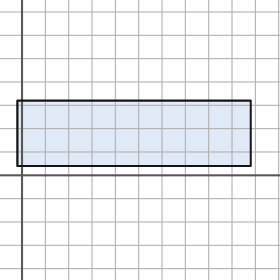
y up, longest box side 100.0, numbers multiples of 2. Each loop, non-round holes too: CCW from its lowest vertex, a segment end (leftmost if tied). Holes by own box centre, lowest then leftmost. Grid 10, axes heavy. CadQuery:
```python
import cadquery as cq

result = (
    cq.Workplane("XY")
    .moveTo(-2.0, 4.0)
    .lineTo(98.0, 4.0)
    .lineTo(98.0, 32.0)
    .lineTo(-2.0, 32.0)
    .close()
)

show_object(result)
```